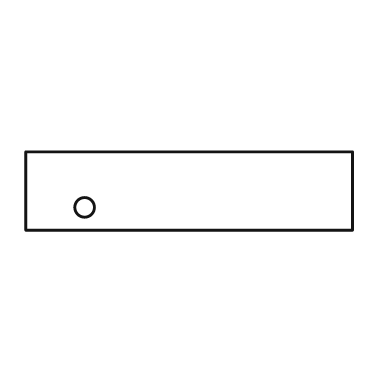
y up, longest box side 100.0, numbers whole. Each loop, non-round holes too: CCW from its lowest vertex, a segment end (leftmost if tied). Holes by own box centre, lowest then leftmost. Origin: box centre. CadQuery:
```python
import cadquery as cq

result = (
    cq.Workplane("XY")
    .moveTo(-50.0, -12.0)
    .lineTo(50.0, -12.0)
    .lineTo(50.0, 12.0)
    .lineTo(-50.0, 12.0)
    .close()
    .moveTo(-32.0, -5.0)
    .circle(3.0)
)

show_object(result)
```